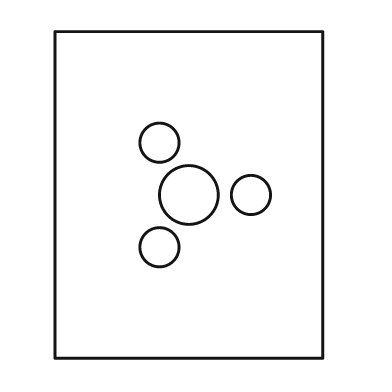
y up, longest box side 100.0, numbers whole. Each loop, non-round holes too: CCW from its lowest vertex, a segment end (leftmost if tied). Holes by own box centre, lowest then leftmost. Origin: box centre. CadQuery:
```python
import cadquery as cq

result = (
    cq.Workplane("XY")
    .moveTo(-41.0, -50.0)
    .lineTo(41.0, -50.0)
    .lineTo(41.0, 50.0)
    .lineTo(-41.0, 50.0)
    .close()
    .moveTo(-9.0, -16.0)
    .circle(6.0)
    .moveTo(0.0, 0.0)
    .circle(9.0)
    .moveTo(19.0, 0.0)
    .circle(6.0)
    .moveTo(-9.0, 16.0)
    .circle(6.0)
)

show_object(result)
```